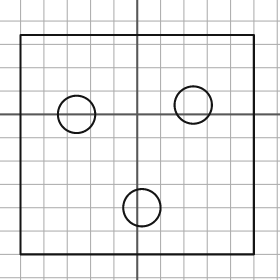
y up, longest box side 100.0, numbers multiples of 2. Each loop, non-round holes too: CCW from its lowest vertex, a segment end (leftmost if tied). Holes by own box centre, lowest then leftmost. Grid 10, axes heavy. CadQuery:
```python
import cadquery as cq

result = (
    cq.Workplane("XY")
    .moveTo(-50.0, -60.0)
    .lineTo(50.0, -60.0)
    .lineTo(50.0, 34.0)
    .lineTo(-50.0, 34.0)
    .close()
    .moveTo(2.0, -40.0)
    .circle(8.0)
    .moveTo(-26.0, 0.0)
    .circle(8.0)
    .moveTo(24.0, 4.0)
    .circle(8.0)
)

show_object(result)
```